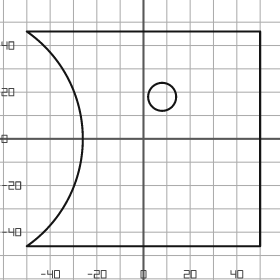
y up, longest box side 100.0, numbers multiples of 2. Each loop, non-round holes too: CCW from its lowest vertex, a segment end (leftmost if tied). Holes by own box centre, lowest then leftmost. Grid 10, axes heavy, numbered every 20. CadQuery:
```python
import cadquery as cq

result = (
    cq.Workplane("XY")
    .moveTo(-50.0, -46.0)
    .lineTo(50.0, -46.0)
    .lineTo(50.0, 46.0)
    .lineTo(-50.0, 46.0)
    .threePointArc((-26.0, 0.0), (-50.0, -46.0))
    .close()
    .moveTo(8.0, 18.0)
    .circle(6.0)
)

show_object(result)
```